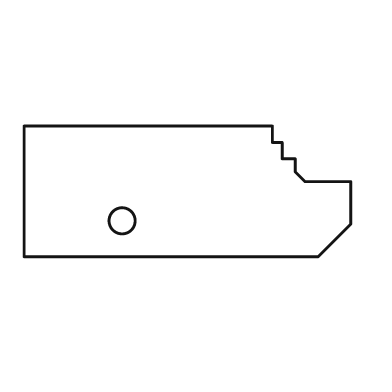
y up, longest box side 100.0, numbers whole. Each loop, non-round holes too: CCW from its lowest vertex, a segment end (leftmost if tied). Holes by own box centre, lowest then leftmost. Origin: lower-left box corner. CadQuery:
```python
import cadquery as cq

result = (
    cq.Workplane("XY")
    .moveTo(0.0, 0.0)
    .lineTo(90.0, 0.0)
    .lineTo(100.0, 10.0)
    .lineTo(100.0, 23.0)
    .lineTo(86.0, 23.0)
    .lineTo(83.0, 26.0)
    .lineTo(83.0, 30.0)
    .lineTo(79.0, 30.0)
    .lineTo(79.0, 35.0)
    .lineTo(76.0, 35.0)
    .lineTo(76.0, 40.0)
    .lineTo(0.0, 40.0)
    .close()
    .moveTo(30.0, 11.0)
    .circle(4.0)
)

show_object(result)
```